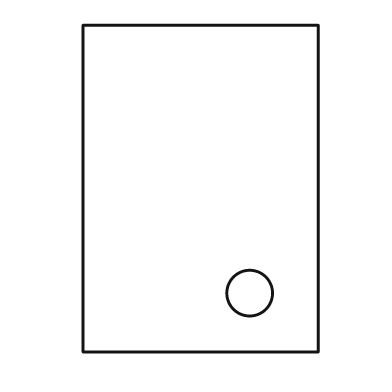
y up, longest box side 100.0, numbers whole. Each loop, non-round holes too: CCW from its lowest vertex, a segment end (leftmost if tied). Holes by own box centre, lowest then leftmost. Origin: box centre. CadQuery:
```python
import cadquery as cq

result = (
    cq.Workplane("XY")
    .moveTo(-36.0, -50.0)
    .lineTo(36.0, -50.0)
    .lineTo(36.0, 50.0)
    .lineTo(-36.0, 50.0)
    .close()
    .moveTo(15.0, -32.0)
    .circle(7.0)
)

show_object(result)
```